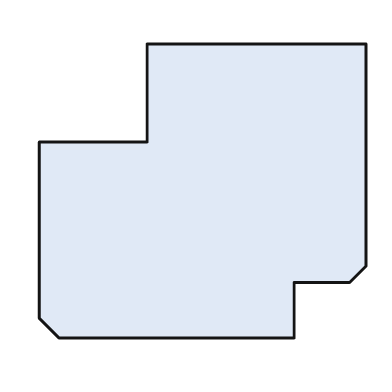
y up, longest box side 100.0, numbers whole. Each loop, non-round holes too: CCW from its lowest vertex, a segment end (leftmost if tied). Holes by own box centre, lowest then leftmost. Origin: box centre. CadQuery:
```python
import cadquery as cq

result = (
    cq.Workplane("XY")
    .moveTo(-44.0, -45.0)
    .lineTo(28.0, -45.0)
    .lineTo(28.0, -28.0)
    .lineTo(45.0, -28.0)
    .lineTo(50.0, -23.0)
    .lineTo(50.0, 45.0)
    .lineTo(-17.0, 45.0)
    .lineTo(-17.0, 15.0)
    .lineTo(-50.0, 15.0)
    .lineTo(-50.0, -39.0)
    .close()
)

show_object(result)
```